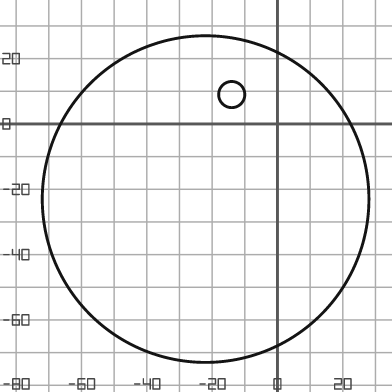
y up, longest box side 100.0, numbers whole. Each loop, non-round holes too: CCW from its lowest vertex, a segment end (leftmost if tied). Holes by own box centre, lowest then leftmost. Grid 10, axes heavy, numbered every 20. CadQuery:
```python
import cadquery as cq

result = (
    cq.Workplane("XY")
    .moveTo(-22.0, -23.0)
    .circle(50.0)
    .moveTo(-14.0, 9.0)
    .circle(4.0)
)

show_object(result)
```